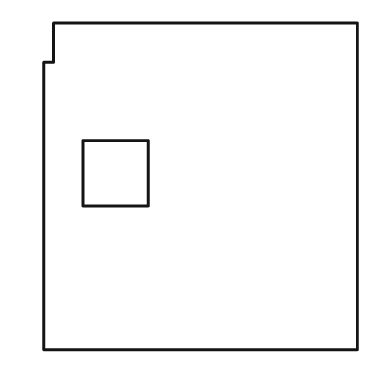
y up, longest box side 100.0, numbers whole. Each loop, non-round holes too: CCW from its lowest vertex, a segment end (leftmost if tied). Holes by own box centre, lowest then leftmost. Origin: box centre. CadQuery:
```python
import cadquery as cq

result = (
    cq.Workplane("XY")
    .moveTo(-48.0, -50.0)
    .lineTo(48.0, -50.0)
    .lineTo(48.0, 50.0)
    .lineTo(-45.0, 50.0)
    .lineTo(-45.0, 38.0)
    .lineTo(-48.0, 38.0)
    .close()
    .moveTo(-36.0, -6.0)
    .lineTo(-16.0, -6.0)
    .lineTo(-16.0, 14.0)
    .lineTo(-36.0, 14.0)
    .close()
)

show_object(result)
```